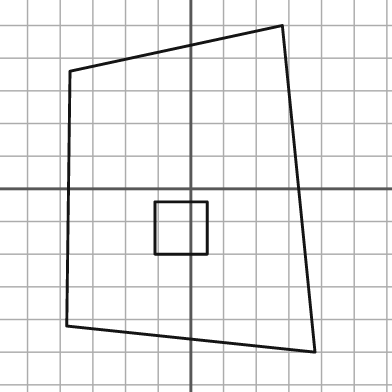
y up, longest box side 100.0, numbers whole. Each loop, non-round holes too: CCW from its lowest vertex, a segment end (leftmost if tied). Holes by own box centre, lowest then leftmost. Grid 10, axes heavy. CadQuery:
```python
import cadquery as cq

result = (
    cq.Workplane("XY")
    .moveTo(38.0, -50.0)
    .lineTo(28.0, 50.0)
    .lineTo(-37.0, 36.0)
    .lineTo(-38.0, -42.0)
    .close()
    .moveTo(-11.0, -20.0)
    .lineTo(5.0, -20.0)
    .lineTo(5.0, -4.0)
    .lineTo(-11.0, -4.0)
    .close()
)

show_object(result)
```